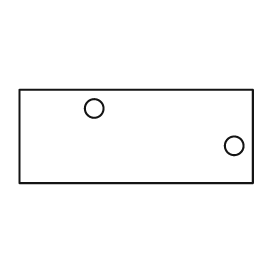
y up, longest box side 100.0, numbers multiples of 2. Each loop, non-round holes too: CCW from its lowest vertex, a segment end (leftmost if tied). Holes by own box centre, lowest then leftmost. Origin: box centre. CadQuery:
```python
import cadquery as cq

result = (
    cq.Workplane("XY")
    .moveTo(-50.0, -20.0)
    .lineTo(50.0, -20.0)
    .lineTo(50.0, 20.0)
    .lineTo(-50.0, 20.0)
    .close()
    .moveTo(42.0, -4.0)
    .circle(4.0)
    .moveTo(-18.0, 12.0)
    .circle(4.0)
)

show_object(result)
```